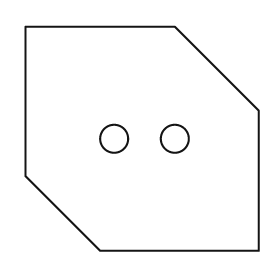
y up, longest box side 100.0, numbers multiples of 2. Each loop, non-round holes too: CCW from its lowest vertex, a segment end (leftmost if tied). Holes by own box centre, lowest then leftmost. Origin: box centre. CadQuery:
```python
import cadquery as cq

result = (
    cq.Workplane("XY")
    .moveTo(-18.0, -48.0)
    .lineTo(50.0, -48.0)
    .lineTo(50.0, 12.0)
    .lineTo(14.0, 48.0)
    .lineTo(-50.0, 48.0)
    .lineTo(-50.0, -16.0)
    .close()
    .moveTo(-12.0, 0.0)
    .circle(6.0)
    .moveTo(14.0, 0.0)
    .circle(6.0)
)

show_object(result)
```